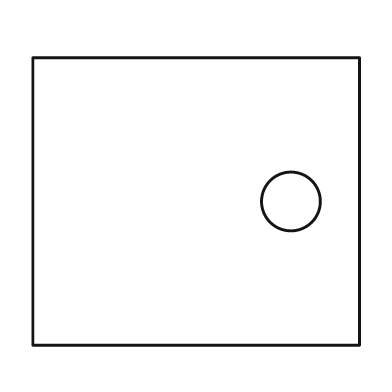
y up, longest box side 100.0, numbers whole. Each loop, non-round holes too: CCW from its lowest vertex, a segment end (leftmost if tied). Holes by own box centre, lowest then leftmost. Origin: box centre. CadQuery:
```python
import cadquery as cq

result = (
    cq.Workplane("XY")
    .moveTo(-50.0, -44.0)
    .lineTo(50.0, -44.0)
    .lineTo(50.0, 44.0)
    .lineTo(-50.0, 44.0)
    .close()
    .moveTo(29.0, 0.0)
    .circle(9.0)
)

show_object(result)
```